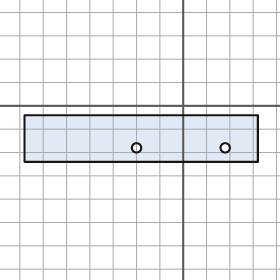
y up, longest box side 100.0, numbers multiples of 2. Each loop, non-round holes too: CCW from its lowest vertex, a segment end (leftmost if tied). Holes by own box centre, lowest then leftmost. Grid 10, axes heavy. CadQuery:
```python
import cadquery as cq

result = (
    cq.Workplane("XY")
    .moveTo(-68.0, -24.0)
    .lineTo(32.0, -24.0)
    .lineTo(32.0, -4.0)
    .lineTo(-68.0, -4.0)
    .close()
    .moveTo(-20.0, -18.0)
    .circle(2.0)
    .moveTo(18.0, -18.0)
    .circle(2.0)
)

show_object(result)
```